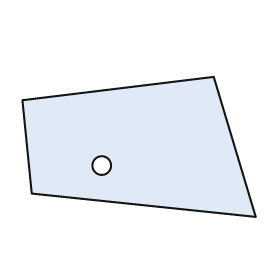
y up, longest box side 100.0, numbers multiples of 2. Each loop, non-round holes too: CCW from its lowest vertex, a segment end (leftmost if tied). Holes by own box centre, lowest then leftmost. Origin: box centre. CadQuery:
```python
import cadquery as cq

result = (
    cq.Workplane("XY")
    .moveTo(50.0, -30.0)
    .lineTo(32.0, 30.0)
    .lineTo(-50.0, 20.0)
    .lineTo(-46.0, -20.0)
    .close()
    .moveTo(-16.0, -8.0)
    .circle(4.0)
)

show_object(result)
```